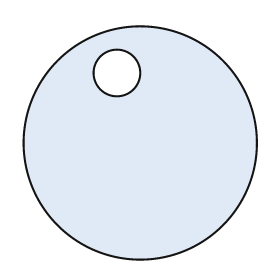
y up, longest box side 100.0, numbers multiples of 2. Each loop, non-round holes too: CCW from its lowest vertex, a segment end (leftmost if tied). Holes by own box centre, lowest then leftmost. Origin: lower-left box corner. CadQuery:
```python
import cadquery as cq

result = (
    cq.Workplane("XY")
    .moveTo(50.0, 50.0)
    .circle(50.0)
    .moveTo(40.0, 80.0)
    .circle(10.0)
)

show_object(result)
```